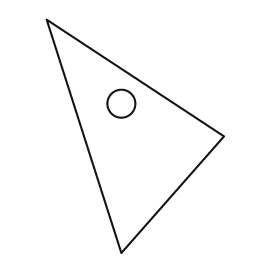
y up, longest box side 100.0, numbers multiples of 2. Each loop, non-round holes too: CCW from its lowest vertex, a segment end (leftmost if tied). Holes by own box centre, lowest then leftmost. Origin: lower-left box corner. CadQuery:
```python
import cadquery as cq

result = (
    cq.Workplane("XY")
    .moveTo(32.0, 0.0)
    .lineTo(76.0, 50.0)
    .lineTo(0.0, 100.0)
    .close()
    .moveTo(32.0, 64.0)
    .circle(6.0)
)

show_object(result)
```